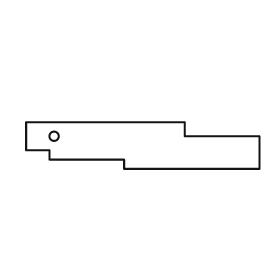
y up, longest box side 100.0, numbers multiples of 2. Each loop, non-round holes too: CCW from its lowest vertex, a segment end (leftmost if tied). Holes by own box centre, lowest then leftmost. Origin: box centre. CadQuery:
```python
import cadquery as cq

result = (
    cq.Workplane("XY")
    .moveTo(-8.0, -10.0)
    .lineTo(50.0, -10.0)
    .lineTo(50.0, 4.0)
    .lineTo(18.0, 4.0)
    .lineTo(18.0, 10.0)
    .lineTo(-50.0, 10.0)
    .lineTo(-50.0, -2.0)
    .lineTo(-40.0, -2.0)
    .lineTo(-40.0, -6.0)
    .lineTo(-8.0, -6.0)
    .close()
    .moveTo(-38.0, 4.0)
    .circle(2.0)
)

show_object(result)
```